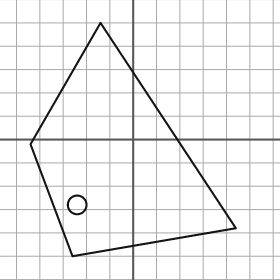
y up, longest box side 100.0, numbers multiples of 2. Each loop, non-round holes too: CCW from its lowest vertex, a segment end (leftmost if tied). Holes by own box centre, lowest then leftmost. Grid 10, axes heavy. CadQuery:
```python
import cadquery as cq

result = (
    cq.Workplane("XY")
    .moveTo(-26.0, -50.0)
    .lineTo(44.0, -38.0)
    .lineTo(-14.0, 50.0)
    .lineTo(-44.0, -2.0)
    .close()
    .moveTo(-24.0, -28.0)
    .circle(4.0)
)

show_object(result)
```